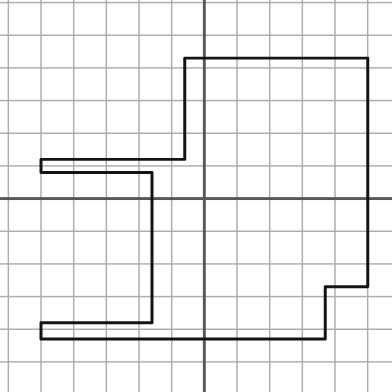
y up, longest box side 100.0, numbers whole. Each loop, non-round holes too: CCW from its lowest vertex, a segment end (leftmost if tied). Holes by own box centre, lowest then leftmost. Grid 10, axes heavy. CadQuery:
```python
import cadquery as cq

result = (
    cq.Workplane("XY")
    .moveTo(-50.0, -43.0)
    .lineTo(37.0, -43.0)
    .lineTo(37.0, -27.0)
    .lineTo(50.0, -27.0)
    .lineTo(50.0, 43.0)
    .lineTo(-6.0, 43.0)
    .lineTo(-6.0, 12.0)
    .lineTo(-50.0, 12.0)
    .lineTo(-50.0, 8.0)
    .lineTo(-16.0, 8.0)
    .lineTo(-16.0, -38.0)
    .lineTo(-50.0, -38.0)
    .close()
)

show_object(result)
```